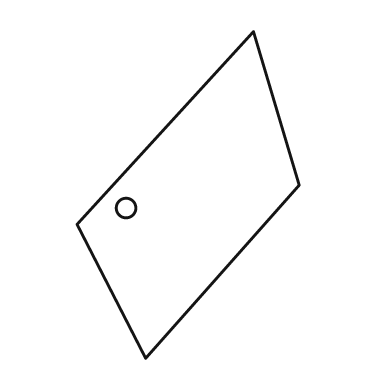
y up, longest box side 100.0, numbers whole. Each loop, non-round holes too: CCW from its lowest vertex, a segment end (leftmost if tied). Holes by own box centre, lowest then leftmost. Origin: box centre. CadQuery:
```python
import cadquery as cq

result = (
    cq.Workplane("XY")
    .moveTo(-13.0, -50.0)
    .lineTo(34.0, 3.0)
    .lineTo(20.0, 50.0)
    .lineTo(-34.0, -9.0)
    .close()
    .moveTo(-19.0, -4.0)
    .circle(3.0)
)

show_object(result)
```